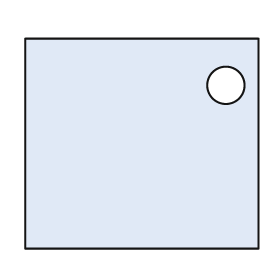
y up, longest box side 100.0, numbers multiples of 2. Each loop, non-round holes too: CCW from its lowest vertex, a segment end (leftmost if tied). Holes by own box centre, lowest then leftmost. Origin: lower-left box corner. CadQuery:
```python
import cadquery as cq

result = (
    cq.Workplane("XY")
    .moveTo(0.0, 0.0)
    .lineTo(100.0, 0.0)
    .lineTo(100.0, 90.0)
    .lineTo(0.0, 90.0)
    .close()
    .moveTo(86.0, 70.0)
    .circle(8.0)
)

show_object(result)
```